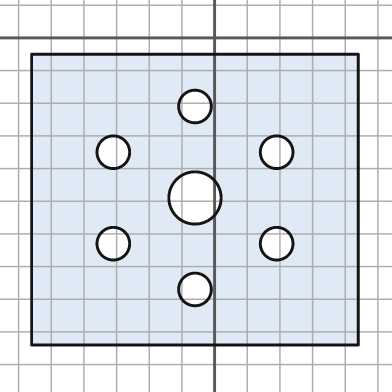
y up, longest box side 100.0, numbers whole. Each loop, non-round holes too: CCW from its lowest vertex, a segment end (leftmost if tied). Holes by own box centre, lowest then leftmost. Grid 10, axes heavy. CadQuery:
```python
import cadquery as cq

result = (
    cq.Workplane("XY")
    .moveTo(-56.0, -94.0)
    .lineTo(44.0, -94.0)
    .lineTo(44.0, -5.0)
    .lineTo(-56.0, -5.0)
    .close()
    .moveTo(-6.0, -77.0)
    .circle(5.0)
    .moveTo(-31.0, -63.0)
    .circle(5.0)
    .moveTo(19.0, -63.0)
    .circle(5.0)
    .moveTo(-6.0, -49.0)
    .circle(8.0)
    .moveTo(-31.0, -35.0)
    .circle(5.0)
    .moveTo(19.0, -35.0)
    .circle(5.0)
    .moveTo(-6.0, -21.0)
    .circle(5.0)
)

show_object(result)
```